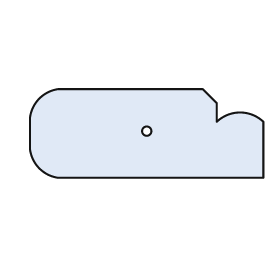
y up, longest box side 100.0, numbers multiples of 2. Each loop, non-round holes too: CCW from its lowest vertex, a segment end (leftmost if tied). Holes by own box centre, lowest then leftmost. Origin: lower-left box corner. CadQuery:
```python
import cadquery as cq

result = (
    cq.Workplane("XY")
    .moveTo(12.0, 0.0)
    .lineTo(100.0, 0.0)
    .lineTo(100.0, 24.0)
    .threePointArc((90.0, 28.0), (80.0, 24.0))
    .lineTo(80.0, 32.0)
    .lineTo(74.0, 38.0)
    .lineTo(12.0, 38.0)
    .threePointArc((4.0, 34.0), (0.0, 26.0))
    .lineTo(0.0, 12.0)
    .threePointArc((4.0, 4.0), (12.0, 0.0))
    .close()
    .moveTo(50.0, 20.0)
    .circle(2.0)
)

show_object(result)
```